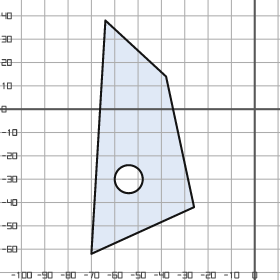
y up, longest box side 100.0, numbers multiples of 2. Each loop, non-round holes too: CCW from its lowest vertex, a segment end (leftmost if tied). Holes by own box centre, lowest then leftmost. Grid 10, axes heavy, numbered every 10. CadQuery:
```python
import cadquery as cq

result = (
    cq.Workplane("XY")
    .moveTo(-70.0, -62.0)
    .lineTo(-26.0, -42.0)
    .lineTo(-38.0, 14.0)
    .lineTo(-64.0, 38.0)
    .close()
    .moveTo(-54.0, -30.0)
    .circle(6.0)
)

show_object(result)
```